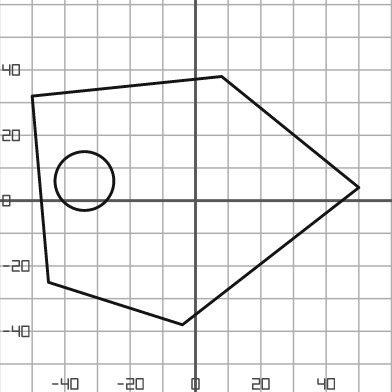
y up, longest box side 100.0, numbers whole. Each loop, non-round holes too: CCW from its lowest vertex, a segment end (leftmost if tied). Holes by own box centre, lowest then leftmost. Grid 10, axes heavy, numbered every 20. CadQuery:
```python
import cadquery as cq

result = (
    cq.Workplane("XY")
    .moveTo(-4.0, -38.0)
    .lineTo(50.0, 4.0)
    .lineTo(8.0, 38.0)
    .lineTo(-50.0, 32.0)
    .lineTo(-45.0, -25.0)
    .close()
    .moveTo(-34.0, 6.0)
    .circle(9.0)
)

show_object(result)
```